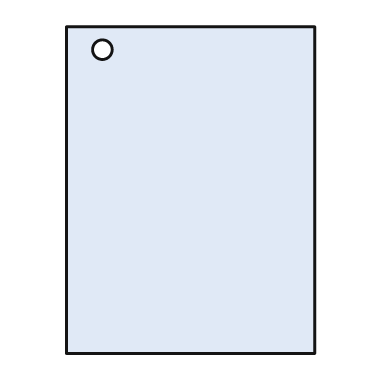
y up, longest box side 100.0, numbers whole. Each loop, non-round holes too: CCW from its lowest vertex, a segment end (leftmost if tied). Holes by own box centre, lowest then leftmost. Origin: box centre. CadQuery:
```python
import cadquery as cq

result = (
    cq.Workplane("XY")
    .moveTo(-38.0, -50.0)
    .lineTo(38.0, -50.0)
    .lineTo(38.0, 50.0)
    .lineTo(-38.0, 50.0)
    .close()
    .moveTo(-27.0, 43.0)
    .circle(3.0)
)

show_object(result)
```